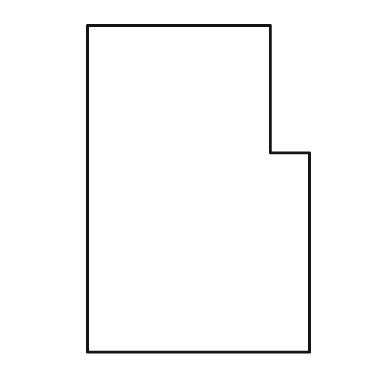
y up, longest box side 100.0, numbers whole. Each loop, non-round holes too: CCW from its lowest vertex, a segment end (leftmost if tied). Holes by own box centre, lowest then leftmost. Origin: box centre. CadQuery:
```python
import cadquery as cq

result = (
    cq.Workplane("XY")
    .moveTo(-34.0, -50.0)
    .lineTo(34.0, -50.0)
    .lineTo(34.0, 11.0)
    .lineTo(22.0, 11.0)
    .lineTo(22.0, 50.0)
    .lineTo(-34.0, 50.0)
    .close()
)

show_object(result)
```